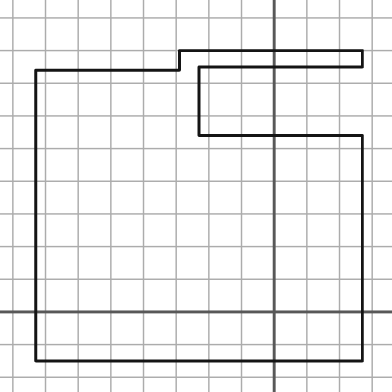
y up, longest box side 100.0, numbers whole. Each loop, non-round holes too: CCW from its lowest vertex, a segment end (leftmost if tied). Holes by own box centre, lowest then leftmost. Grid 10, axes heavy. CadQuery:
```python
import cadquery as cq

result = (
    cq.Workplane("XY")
    .moveTo(-73.0, -15.0)
    .lineTo(27.0, -15.0)
    .lineTo(27.0, 54.0)
    .lineTo(-23.0, 54.0)
    .lineTo(-23.0, 75.0)
    .lineTo(27.0, 75.0)
    .lineTo(27.0, 80.0)
    .lineTo(-29.0, 80.0)
    .lineTo(-29.0, 74.0)
    .lineTo(-73.0, 74.0)
    .close()
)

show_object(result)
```